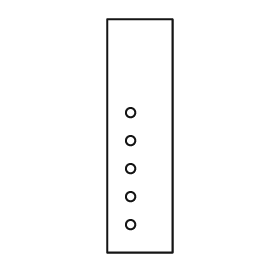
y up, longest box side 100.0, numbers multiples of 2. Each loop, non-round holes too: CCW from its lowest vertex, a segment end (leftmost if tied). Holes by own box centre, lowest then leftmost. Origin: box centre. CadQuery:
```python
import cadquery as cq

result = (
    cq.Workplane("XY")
    .moveTo(-14.0, -50.0)
    .lineTo(14.0, -50.0)
    .lineTo(14.0, 50.0)
    .lineTo(-14.0, 50.0)
    .close()
    .moveTo(-4.0, -38.0)
    .circle(2.0)
    .moveTo(-4.0, -26.0)
    .circle(2.0)
    .moveTo(-4.0, -14.0)
    .circle(2.0)
    .moveTo(-4.0, -2.0)
    .circle(2.0)
    .moveTo(-4.0, 10.0)
    .circle(2.0)
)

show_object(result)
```